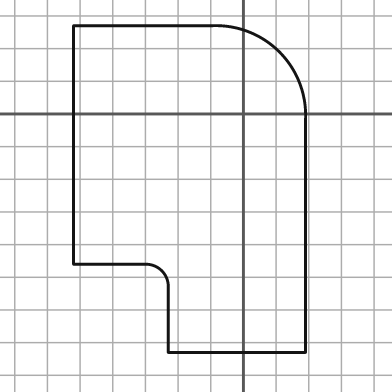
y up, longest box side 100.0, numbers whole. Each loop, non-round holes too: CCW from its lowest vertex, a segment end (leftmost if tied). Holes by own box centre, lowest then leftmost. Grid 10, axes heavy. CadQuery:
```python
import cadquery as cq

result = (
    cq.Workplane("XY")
    .moveTo(-23.0, -73.0)
    .lineTo(19.0, -73.0)
    .lineTo(19.0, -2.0)
    .threePointArc((11.0, 19.0), (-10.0, 27.0))
    .lineTo(-52.0, 27.0)
    .lineTo(-52.0, -46.0)
    .lineTo(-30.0, -46.0)
    .threePointArc((-25.0, -48.0), (-23.0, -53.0))
    .close()
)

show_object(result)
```